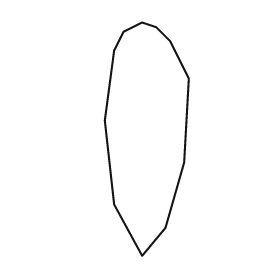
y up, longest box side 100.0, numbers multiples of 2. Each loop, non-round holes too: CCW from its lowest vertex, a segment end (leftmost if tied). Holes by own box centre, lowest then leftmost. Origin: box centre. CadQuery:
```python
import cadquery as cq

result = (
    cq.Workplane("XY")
    .moveTo(-2.0, -50.0)
    .lineTo(8.0, -38.0)
    .lineTo(16.0, -10.0)
    .lineTo(18.0, 26.0)
    .lineTo(10.0, 42.0)
    .lineTo(4.0, 48.0)
    .lineTo(-2.0, 50.0)
    .lineTo(-10.0, 46.0)
    .lineTo(-14.0, 38.0)
    .lineTo(-18.0, 8.0)
    .lineTo(-14.0, -28.0)
    .close()
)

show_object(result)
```